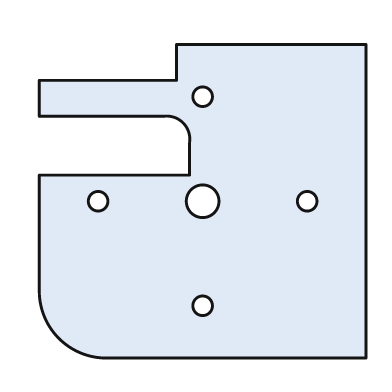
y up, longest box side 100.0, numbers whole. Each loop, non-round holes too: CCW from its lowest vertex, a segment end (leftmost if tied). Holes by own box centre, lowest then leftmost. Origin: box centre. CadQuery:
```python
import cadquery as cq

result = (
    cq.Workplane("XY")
    .moveTo(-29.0, -48.0)
    .lineTo(50.0, -48.0)
    .lineTo(50.0, 48.0)
    .lineTo(-8.0, 48.0)
    .lineTo(-8.0, 37.0)
    .lineTo(-50.0, 37.0)
    .lineTo(-50.0, 26.0)
    .lineTo(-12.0, 26.0)
    .threePointArc((-6.0, 24.0), (-4.0, 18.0))
    .lineTo(-4.0, 8.0)
    .lineTo(-50.0, 8.0)
    .lineTo(-50.0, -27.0)
    .threePointArc((-44.0, -42.0), (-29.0, -48.0))
    .close()
    .moveTo(0.0, -32.0)
    .circle(3.0)
    .moveTo(-32.0, 0.0)
    .circle(3.0)
    .moveTo(0.0, 0.0)
    .circle(5.0)
    .moveTo(32.0, 0.0)
    .circle(3.0)
    .moveTo(0.0, 32.0)
    .circle(3.0)
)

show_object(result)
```